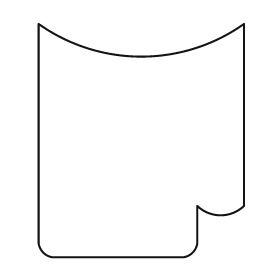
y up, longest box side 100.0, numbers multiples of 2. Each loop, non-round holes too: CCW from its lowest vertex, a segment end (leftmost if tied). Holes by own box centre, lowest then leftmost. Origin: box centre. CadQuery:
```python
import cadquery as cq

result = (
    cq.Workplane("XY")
    .moveTo(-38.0, -50.0)
    .lineTo(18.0, -50.0)
    .threePointArc((22.0, -48.0), (24.0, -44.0))
    .lineTo(24.0, -28.0)
    .threePointArc((34.0, -32.0), (44.0, -28.0))
    .lineTo(44.0, 50.0)
    .threePointArc((0.0, 36.0), (-44.0, 50.0))
    .lineTo(-44.0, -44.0)
    .threePointArc((-42.0, -48.0), (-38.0, -50.0))
    .close()
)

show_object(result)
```